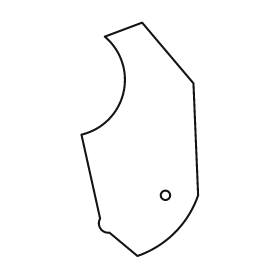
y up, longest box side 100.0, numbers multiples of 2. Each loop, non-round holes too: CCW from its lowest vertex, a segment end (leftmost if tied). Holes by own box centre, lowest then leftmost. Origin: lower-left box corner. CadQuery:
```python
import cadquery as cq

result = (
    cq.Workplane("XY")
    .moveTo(24.0, 0.0)
    .threePointArc((40.0, 10.0), (50.0, 26.0))
    .lineTo(48.0, 74.0)
    .lineTo(26.0, 100.0)
    .lineTo(10.0, 94.0)
    .threePointArc((18.0, 70.0), (0.0, 52.0))
    .lineTo(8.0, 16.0)
    .threePointArc((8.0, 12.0), (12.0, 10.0))
    .close()
    .moveTo(36.0, 26.0)
    .circle(2.0)
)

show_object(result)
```